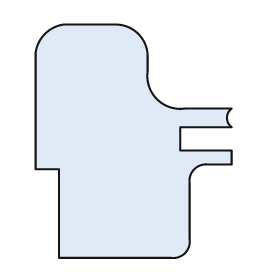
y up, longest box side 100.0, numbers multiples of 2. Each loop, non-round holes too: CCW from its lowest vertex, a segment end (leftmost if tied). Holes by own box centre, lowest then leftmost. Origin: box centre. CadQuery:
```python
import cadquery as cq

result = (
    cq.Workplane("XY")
    .moveTo(-32.0, -50.0)
    .lineTo(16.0, -50.0)
    .threePointArc((22.0, -48.0), (24.0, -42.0))
    .lineTo(24.0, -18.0)
    .threePointArc((26.0, -12.0), (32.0, -10.0))
    .lineTo(42.0, -10.0)
    .lineTo(42.0, -4.0)
    .lineTo(20.0, -4.0)
    .lineTo(20.0, 6.0)
    .lineTo(42.0, 6.0)
    .threePointArc((40.0, 10.0), (42.0, 14.0))
    .lineTo(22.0, 14.0)
    .threePointArc((10.0, 18.0), (6.0, 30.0))
    .lineTo(6.0, 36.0)
    .threePointArc((2.0, 46.0), (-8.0, 50.0))
    .lineTo(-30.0, 50.0)
    .threePointArc((-38.0, 46.0), (-42.0, 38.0))
    .lineTo(-42.0, -12.0)
    .lineTo(-32.0, -12.0)
    .close()
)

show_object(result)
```